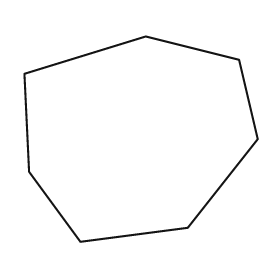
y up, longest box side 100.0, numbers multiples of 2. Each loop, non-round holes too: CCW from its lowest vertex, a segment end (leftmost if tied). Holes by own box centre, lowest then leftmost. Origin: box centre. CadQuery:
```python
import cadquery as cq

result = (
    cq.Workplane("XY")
    .moveTo(-26.0, -44.0)
    .lineTo(20.0, -38.0)
    .lineTo(50.0, 0.0)
    .lineTo(42.0, 34.0)
    .lineTo(2.0, 44.0)
    .lineTo(-50.0, 28.0)
    .lineTo(-48.0, -14.0)
    .close()
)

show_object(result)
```